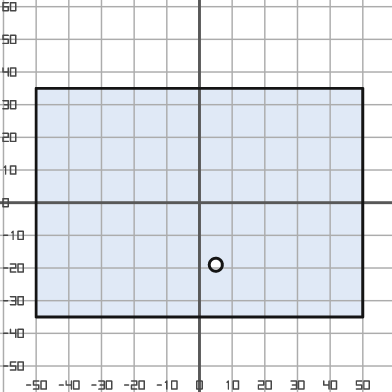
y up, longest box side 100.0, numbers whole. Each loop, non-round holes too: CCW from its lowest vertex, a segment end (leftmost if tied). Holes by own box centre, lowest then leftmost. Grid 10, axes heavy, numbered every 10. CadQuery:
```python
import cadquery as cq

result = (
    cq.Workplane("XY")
    .moveTo(-50.0, -35.0)
    .lineTo(50.0, -35.0)
    .lineTo(50.0, 35.0)
    .lineTo(-50.0, 35.0)
    .close()
    .moveTo(5.0, -19.0)
    .circle(2.0)
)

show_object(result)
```